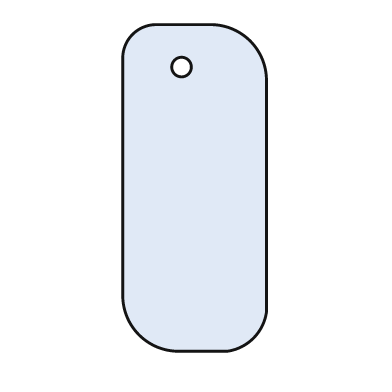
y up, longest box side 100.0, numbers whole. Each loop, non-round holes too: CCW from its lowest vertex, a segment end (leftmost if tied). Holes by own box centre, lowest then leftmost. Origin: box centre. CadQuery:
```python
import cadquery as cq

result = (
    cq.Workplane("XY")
    .moveTo(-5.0, -50.0)
    .lineTo(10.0, -50.0)
    .threePointArc((18.0, -46.0), (22.0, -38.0))
    .lineTo(22.0, 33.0)
    .threePointArc((17.0, 45.0), (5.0, 50.0))
    .lineTo(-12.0, 50.0)
    .threePointArc((-19.0, 47.0), (-22.0, 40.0))
    .lineTo(-22.0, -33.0)
    .threePointArc((-17.0, -45.0), (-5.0, -50.0))
    .close()
    .moveTo(-4.0, 37.0)
    .circle(3.0)
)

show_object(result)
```